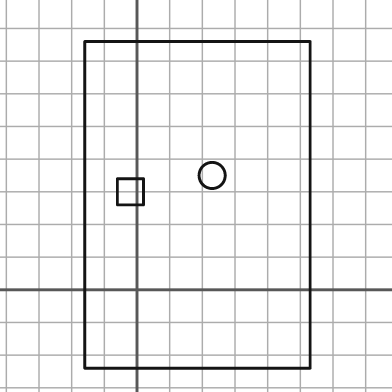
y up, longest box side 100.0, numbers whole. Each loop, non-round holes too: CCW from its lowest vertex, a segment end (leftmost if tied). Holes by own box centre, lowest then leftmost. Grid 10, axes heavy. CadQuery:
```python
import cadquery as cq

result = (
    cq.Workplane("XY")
    .moveTo(-16.0, -24.0)
    .lineTo(53.0, -24.0)
    .lineTo(53.0, 76.0)
    .lineTo(-16.0, 76.0)
    .close()
    .moveTo(-6.0, 26.0)
    .lineTo(2.0, 26.0)
    .lineTo(2.0, 34.0)
    .lineTo(-6.0, 34.0)
    .close()
    .moveTo(23.0, 35.0)
    .circle(4.0)
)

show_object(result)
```